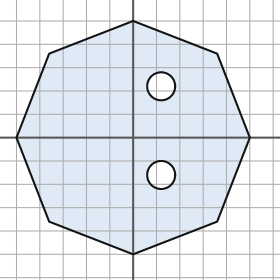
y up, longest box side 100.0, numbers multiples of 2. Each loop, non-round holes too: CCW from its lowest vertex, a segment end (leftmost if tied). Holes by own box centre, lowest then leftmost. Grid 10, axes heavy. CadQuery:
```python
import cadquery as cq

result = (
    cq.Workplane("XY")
    .moveTo(0.0, -50.0)
    .lineTo(36.0, -36.0)
    .lineTo(50.0, 0.0)
    .lineTo(36.0, 36.0)
    .lineTo(0.0, 50.0)
    .lineTo(-36.0, 36.0)
    .lineTo(-50.0, 0.0)
    .lineTo(-36.0, -36.0)
    .close()
    .moveTo(12.0, -16.0)
    .circle(6.0)
    .moveTo(12.0, 22.0)
    .circle(6.0)
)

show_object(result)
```